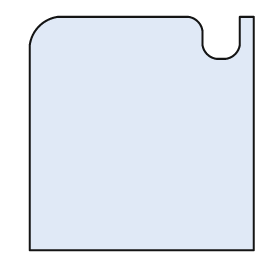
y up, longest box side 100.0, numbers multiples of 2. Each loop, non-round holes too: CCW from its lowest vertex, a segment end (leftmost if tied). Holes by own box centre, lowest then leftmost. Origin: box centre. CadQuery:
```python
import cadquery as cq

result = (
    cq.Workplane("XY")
    .moveTo(-48.0, -50.0)
    .lineTo(48.0, -50.0)
    .lineTo(48.0, 50.0)
    .lineTo(42.0, 50.0)
    .lineTo(42.0, 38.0)
    .threePointArc((40.0, 34.0), (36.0, 32.0))
    .lineTo(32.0, 32.0)
    .threePointArc((28.0, 34.0), (26.0, 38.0))
    .lineTo(26.0, 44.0)
    .threePointArc((24.0, 48.0), (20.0, 50.0))
    .lineTo(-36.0, 50.0)
    .threePointArc((-44.0, 46.0), (-48.0, 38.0))
    .close()
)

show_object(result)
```